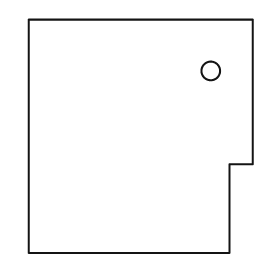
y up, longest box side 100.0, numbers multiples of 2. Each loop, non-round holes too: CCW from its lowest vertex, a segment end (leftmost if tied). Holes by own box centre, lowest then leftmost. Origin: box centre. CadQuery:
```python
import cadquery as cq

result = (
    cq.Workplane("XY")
    .moveTo(-48.0, -50.0)
    .lineTo(38.0, -50.0)
    .lineTo(38.0, -12.0)
    .lineTo(48.0, -12.0)
    .lineTo(48.0, 50.0)
    .lineTo(-48.0, 50.0)
    .close()
    .moveTo(30.0, 28.0)
    .circle(4.0)
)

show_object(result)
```